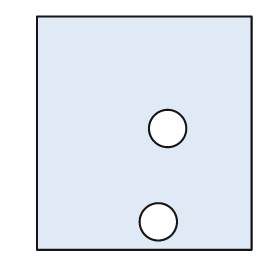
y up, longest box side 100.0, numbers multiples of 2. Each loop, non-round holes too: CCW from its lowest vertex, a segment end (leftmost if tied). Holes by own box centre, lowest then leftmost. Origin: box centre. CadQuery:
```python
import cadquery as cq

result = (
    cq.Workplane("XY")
    .moveTo(-46.0, -50.0)
    .lineTo(46.0, -50.0)
    .lineTo(46.0, 50.0)
    .lineTo(-46.0, 50.0)
    .close()
    .moveTo(6.0, -38.0)
    .circle(8.0)
    .moveTo(10.0, 2.0)
    .circle(8.0)
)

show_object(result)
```